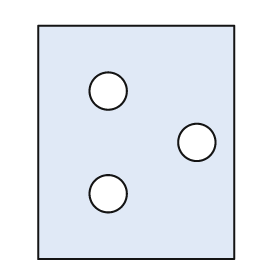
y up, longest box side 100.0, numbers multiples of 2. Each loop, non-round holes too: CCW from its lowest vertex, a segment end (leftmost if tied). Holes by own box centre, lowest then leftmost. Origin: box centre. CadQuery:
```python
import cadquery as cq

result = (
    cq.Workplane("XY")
    .moveTo(-42.0, -50.0)
    .lineTo(42.0, -50.0)
    .lineTo(42.0, 50.0)
    .lineTo(-42.0, 50.0)
    .close()
    .moveTo(-12.0, -22.0)
    .circle(8.0)
    .moveTo(26.0, 0.0)
    .circle(8.0)
    .moveTo(-12.0, 22.0)
    .circle(8.0)
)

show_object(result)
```